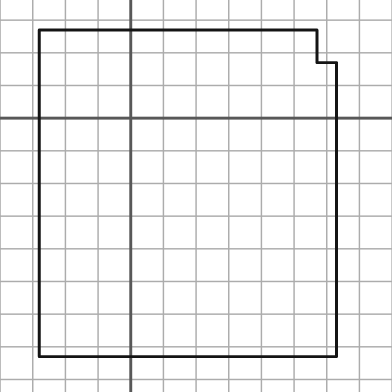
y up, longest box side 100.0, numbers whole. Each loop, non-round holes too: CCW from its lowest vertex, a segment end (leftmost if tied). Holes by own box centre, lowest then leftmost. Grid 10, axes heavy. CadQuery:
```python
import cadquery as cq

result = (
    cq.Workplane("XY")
    .moveTo(-28.0, -73.0)
    .lineTo(63.0, -73.0)
    .lineTo(63.0, 17.0)
    .lineTo(57.0, 17.0)
    .lineTo(57.0, 27.0)
    .lineTo(-28.0, 27.0)
    .close()
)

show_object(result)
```